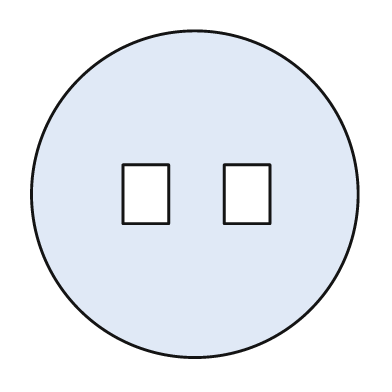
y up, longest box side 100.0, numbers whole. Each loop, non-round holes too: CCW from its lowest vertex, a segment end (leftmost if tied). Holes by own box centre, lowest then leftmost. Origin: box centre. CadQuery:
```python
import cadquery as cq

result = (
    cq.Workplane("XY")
    .moveTo(0.0, 0.0)
    .circle(50.0)
    .moveTo(-22.0, -9.0)
    .lineTo(-8.0, -9.0)
    .lineTo(-8.0, 9.0)
    .lineTo(-22.0, 9.0)
    .close()
    .moveTo(9.0, -9.0)
    .lineTo(23.0, -9.0)
    .lineTo(23.0, 9.0)
    .lineTo(9.0, 9.0)
    .close()
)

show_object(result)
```